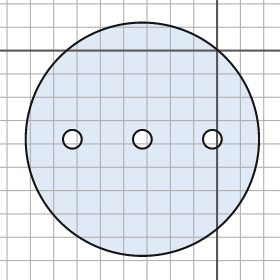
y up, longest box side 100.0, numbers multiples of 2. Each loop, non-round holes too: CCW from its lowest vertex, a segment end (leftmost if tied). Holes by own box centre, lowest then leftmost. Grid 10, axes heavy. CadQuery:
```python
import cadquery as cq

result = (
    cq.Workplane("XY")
    .moveTo(-32.0, -38.0)
    .circle(50.0)
    .moveTo(-62.0, -38.0)
    .circle(4.0)
    .moveTo(-32.0, -38.0)
    .circle(4.0)
    .moveTo(-2.0, -38.0)
    .circle(4.0)
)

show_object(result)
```